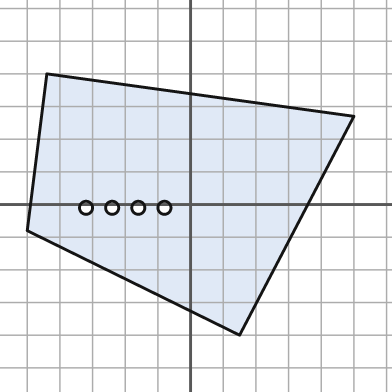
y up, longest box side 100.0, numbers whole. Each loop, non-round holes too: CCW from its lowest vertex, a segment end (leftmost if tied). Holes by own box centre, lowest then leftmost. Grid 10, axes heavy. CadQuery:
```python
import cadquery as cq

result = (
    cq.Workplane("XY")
    .moveTo(15.0, -40.0)
    .lineTo(50.0, 27.0)
    .lineTo(-44.0, 40.0)
    .lineTo(-50.0, -8.0)
    .close()
    .moveTo(-32.0, -1.0)
    .circle(2.0)
    .moveTo(-24.0, -1.0)
    .circle(2.0)
    .moveTo(-16.0, -1.0)
    .circle(2.0)
    .moveTo(-8.0, -1.0)
    .circle(2.0)
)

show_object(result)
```